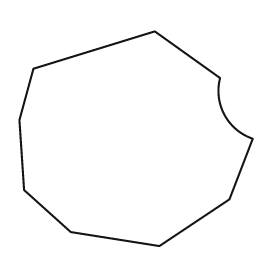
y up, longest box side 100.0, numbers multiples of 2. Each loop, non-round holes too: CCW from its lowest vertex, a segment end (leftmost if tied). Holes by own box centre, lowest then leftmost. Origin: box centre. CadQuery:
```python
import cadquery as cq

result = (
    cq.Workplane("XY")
    .moveTo(10.0, -46.0)
    .lineTo(40.0, -26.0)
    .lineTo(50.0, 0.0)
    .threePointArc((38.0, 10.0), (36.0, 26.0))
    .lineTo(8.0, 46.0)
    .lineTo(-44.0, 30.0)
    .lineTo(-50.0, 8.0)
    .lineTo(-48.0, -22.0)
    .lineTo(-28.0, -40.0)
    .close()
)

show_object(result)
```